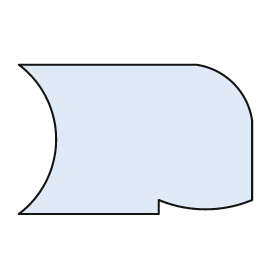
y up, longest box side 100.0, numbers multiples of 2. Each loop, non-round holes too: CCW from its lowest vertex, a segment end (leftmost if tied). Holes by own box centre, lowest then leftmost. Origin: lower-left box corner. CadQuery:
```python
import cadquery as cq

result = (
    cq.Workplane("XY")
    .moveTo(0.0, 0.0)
    .lineTo(60.0, 0.0)
    .lineTo(60.0, 6.0)
    .threePointArc((80.0, 2.0), (100.0, 6.0))
    .lineTo(100.0, 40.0)
    .threePointArc((92.0, 56.0), (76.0, 64.0))
    .lineTo(0.0, 64.0)
    .threePointArc((16.0, 32.0), (0.0, 0.0))
    .close()
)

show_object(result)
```